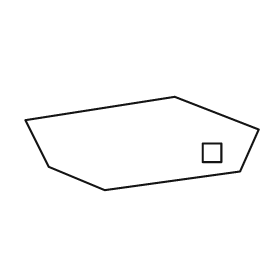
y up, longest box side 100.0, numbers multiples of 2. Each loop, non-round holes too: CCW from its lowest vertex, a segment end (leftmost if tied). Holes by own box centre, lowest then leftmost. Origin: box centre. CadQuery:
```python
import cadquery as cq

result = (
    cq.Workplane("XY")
    .moveTo(-16.0, -20.0)
    .lineTo(42.0, -12.0)
    .lineTo(50.0, 6.0)
    .lineTo(14.0, 20.0)
    .lineTo(-50.0, 10.0)
    .lineTo(-40.0, -10.0)
    .close()
    .moveTo(26.0, -8.0)
    .lineTo(34.0, -8.0)
    .lineTo(34.0, 0.0)
    .lineTo(26.0, 0.0)
    .close()
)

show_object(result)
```